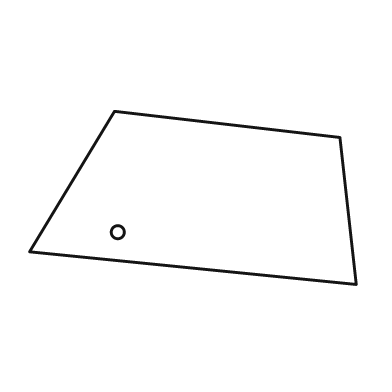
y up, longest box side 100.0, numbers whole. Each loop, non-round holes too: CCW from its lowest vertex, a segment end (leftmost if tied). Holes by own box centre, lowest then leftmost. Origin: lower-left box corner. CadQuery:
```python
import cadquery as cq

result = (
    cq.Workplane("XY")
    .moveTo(100.0, 0.0)
    .lineTo(95.0, 45.0)
    .lineTo(26.0, 53.0)
    .lineTo(0.0, 10.0)
    .close()
    .moveTo(27.0, 16.0)
    .circle(2.0)
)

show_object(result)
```